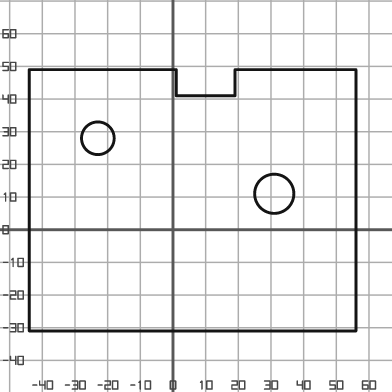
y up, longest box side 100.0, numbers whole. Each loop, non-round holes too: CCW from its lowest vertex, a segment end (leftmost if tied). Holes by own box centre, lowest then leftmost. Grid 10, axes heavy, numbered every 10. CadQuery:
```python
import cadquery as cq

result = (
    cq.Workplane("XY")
    .moveTo(-44.0, -31.0)
    .lineTo(56.0, -31.0)
    .lineTo(56.0, 49.0)
    .lineTo(19.0, 49.0)
    .lineTo(19.0, 41.0)
    .lineTo(1.0, 41.0)
    .lineTo(1.0, 49.0)
    .lineTo(-44.0, 49.0)
    .close()
    .moveTo(31.0, 11.0)
    .circle(6.0)
    .moveTo(-23.0, 28.0)
    .circle(5.0)
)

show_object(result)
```